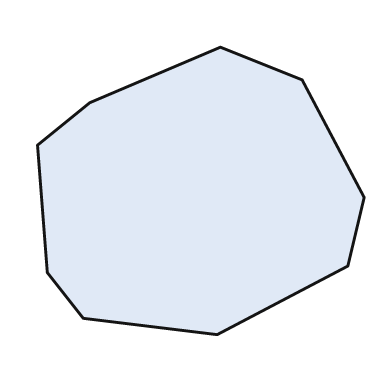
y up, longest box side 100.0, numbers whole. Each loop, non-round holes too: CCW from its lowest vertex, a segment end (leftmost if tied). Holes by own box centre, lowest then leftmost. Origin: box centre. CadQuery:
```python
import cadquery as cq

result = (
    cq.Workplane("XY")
    .moveTo(5.0, -44.0)
    .lineTo(45.0, -23.0)
    .lineTo(50.0, -2.0)
    .lineTo(31.0, 34.0)
    .lineTo(6.0, 44.0)
    .lineTo(-34.0, 27.0)
    .lineTo(-50.0, 14.0)
    .lineTo(-47.0, -25.0)
    .lineTo(-36.0, -39.0)
    .close()
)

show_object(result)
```